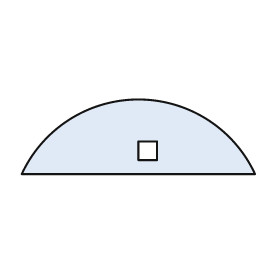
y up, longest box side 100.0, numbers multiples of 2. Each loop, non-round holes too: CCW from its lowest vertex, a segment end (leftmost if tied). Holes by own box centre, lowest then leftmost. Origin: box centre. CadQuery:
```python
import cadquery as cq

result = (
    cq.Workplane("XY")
    .moveTo(-50.0, -16.0)
    .lineTo(50.0, -16.0)
    .threePointArc((0.0, 16.0), (-50.0, -16.0))
    .close()
    .moveTo(0.0, -10.0)
    .lineTo(8.0, -10.0)
    .lineTo(8.0, -2.0)
    .lineTo(0.0, -2.0)
    .close()
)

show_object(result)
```